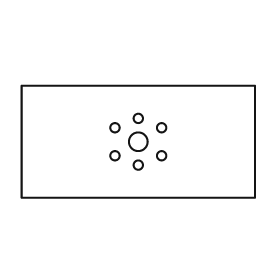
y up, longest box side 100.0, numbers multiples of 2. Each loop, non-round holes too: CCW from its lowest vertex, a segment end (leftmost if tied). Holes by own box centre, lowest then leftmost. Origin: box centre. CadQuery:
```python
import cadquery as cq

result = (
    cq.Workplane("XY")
    .moveTo(-50.0, -24.0)
    .lineTo(50.0, -24.0)
    .lineTo(50.0, 24.0)
    .lineTo(-50.0, 24.0)
    .close()
    .moveTo(0.0, -10.0)
    .circle(2.0)
    .moveTo(-10.0, -6.0)
    .circle(2.0)
    .moveTo(10.0, -6.0)
    .circle(2.0)
    .moveTo(0.0, 0.0)
    .circle(4.0)
    .moveTo(-10.0, 6.0)
    .circle(2.0)
    .moveTo(10.0, 6.0)
    .circle(2.0)
    .moveTo(0.0, 10.0)
    .circle(2.0)
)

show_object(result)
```